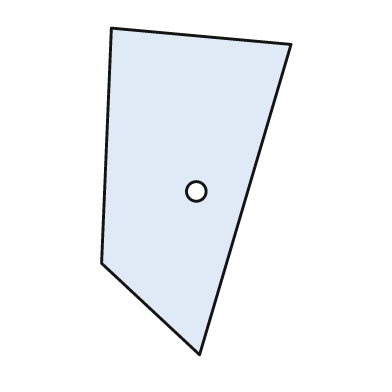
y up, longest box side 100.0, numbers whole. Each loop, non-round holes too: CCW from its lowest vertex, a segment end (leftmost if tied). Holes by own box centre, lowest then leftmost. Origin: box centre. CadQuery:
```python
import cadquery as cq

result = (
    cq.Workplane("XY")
    .moveTo(1.0, -50.0)
    .lineTo(29.0, 45.0)
    .lineTo(-26.0, 50.0)
    .lineTo(-29.0, -22.0)
    .close()
    .moveTo(0.0, 0.0)
    .circle(3.0)
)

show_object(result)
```